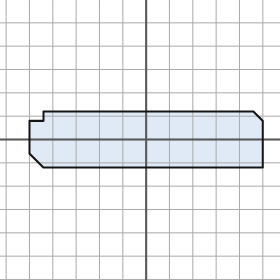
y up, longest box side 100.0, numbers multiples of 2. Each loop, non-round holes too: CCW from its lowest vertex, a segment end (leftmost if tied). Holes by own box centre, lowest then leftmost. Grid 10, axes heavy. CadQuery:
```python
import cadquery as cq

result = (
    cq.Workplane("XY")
    .moveTo(-44.0, -12.0)
    .lineTo(50.0, -12.0)
    .lineTo(50.0, 8.0)
    .lineTo(46.0, 12.0)
    .lineTo(-44.0, 12.0)
    .lineTo(-44.0, 8.0)
    .lineTo(-50.0, 8.0)
    .lineTo(-50.0, -6.0)
    .close()
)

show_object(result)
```